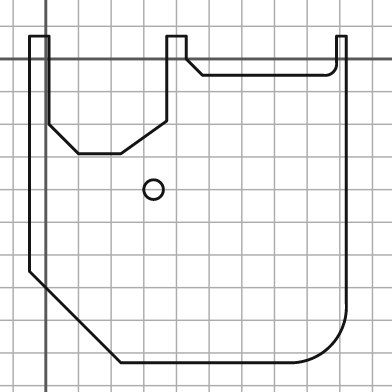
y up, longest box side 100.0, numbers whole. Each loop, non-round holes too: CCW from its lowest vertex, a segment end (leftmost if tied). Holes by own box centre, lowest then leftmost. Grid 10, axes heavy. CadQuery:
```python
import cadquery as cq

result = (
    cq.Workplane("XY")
    .moveTo(23.0, -93.0)
    .lineTo(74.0, -93.0)
    .threePointArc((87.0, -88.0), (92.0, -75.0))
    .lineTo(92.0, 7.0)
    .lineTo(89.0, 7.0)
    .lineTo(89.0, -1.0)
    .threePointArc((88.0, -4.0), (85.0, -5.0))
    .lineTo(48.0, -5.0)
    .lineTo(43.0, 0.0)
    .lineTo(43.0, 7.0)
    .lineTo(37.0, 7.0)
    .lineTo(37.0, -19.0)
    .lineTo(23.0, -29.0)
    .lineTo(10.0, -29.0)
    .lineTo(1.0, -20.0)
    .lineTo(1.0, 7.0)
    .lineTo(-5.0, 7.0)
    .lineTo(-5.0, -65.0)
    .close()
    .moveTo(33.0, -40.0)
    .circle(3.0)
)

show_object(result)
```